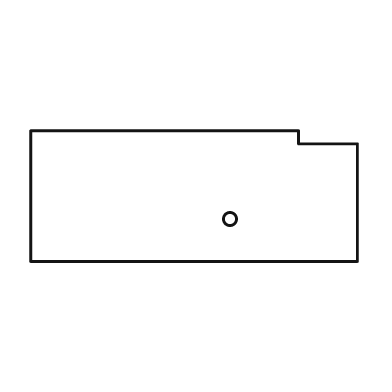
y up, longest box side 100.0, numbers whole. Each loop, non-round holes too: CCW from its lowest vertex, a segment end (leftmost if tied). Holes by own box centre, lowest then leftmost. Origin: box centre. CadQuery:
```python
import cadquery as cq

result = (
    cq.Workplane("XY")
    .moveTo(-50.0, -20.0)
    .lineTo(50.0, -20.0)
    .lineTo(50.0, 16.0)
    .lineTo(32.0, 16.0)
    .lineTo(32.0, 20.0)
    .lineTo(-50.0, 20.0)
    .close()
    .moveTo(11.0, -7.0)
    .circle(2.0)
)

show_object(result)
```